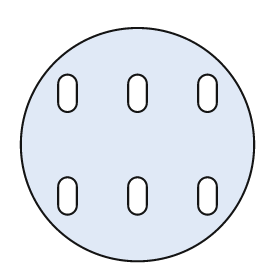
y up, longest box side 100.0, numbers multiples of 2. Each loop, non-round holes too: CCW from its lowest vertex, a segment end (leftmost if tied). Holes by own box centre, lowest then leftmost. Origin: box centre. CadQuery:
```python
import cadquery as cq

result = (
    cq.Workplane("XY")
    .moveTo(0.0, 0.0)
    .circle(50.0)
    .moveTo(-34.0, -26.0)
    .threePointArc((-30.0, -30.0), (-26.0, -26.0))
    .lineTo(-26.0, -18.0)
    .threePointArc((-30.0, -14.0), (-34.0, -18.0))
    .close()
    .moveTo(-4.0, -26.0)
    .threePointArc((0.0, -30.0), (4.0, -26.0))
    .lineTo(4.0, -18.0)
    .threePointArc((0.0, -14.0), (-4.0, -18.0))
    .close()
    .moveTo(26.0, -26.0)
    .threePointArc((30.0, -30.0), (34.0, -26.0))
    .lineTo(34.0, -18.0)
    .threePointArc((30.0, -14.0), (26.0, -18.0))
    .close()
    .moveTo(-34.0, 18.0)
    .threePointArc((-30.0, 14.0), (-26.0, 18.0))
    .lineTo(-26.0, 26.0)
    .threePointArc((-30.0, 30.0), (-34.0, 26.0))
    .close()
    .moveTo(-4.0, 18.0)
    .threePointArc((0.0, 14.0), (4.0, 18.0))
    .lineTo(4.0, 26.0)
    .threePointArc((0.0, 30.0), (-4.0, 26.0))
    .close()
    .moveTo(26.0, 18.0)
    .threePointArc((30.0, 14.0), (34.0, 18.0))
    .lineTo(34.0, 26.0)
    .threePointArc((30.0, 30.0), (26.0, 26.0))
    .close()
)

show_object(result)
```